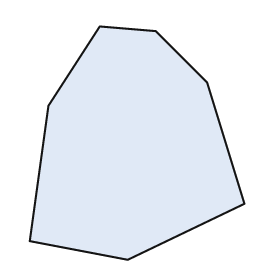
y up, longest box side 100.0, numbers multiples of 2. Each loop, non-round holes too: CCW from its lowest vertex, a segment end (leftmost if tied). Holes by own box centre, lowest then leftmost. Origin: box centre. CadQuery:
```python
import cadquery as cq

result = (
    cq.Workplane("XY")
    .moveTo(-4.0, -50.0)
    .lineTo(46.0, -26.0)
    .lineTo(30.0, 26.0)
    .lineTo(8.0, 48.0)
    .lineTo(-16.0, 50.0)
    .lineTo(-38.0, 16.0)
    .lineTo(-46.0, -42.0)
    .close()
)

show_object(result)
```